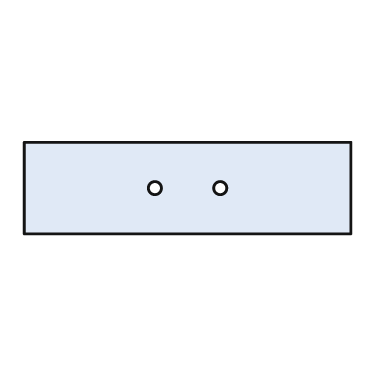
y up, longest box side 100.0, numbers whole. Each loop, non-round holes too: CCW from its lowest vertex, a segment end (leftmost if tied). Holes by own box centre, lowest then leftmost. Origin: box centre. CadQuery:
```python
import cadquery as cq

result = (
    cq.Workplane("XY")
    .moveTo(-50.0, -14.0)
    .lineTo(50.0, -14.0)
    .lineTo(50.0, 14.0)
    .lineTo(-50.0, 14.0)
    .close()
    .moveTo(-10.0, 0.0)
    .circle(2.0)
    .moveTo(10.0, 0.0)
    .circle(2.0)
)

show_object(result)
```